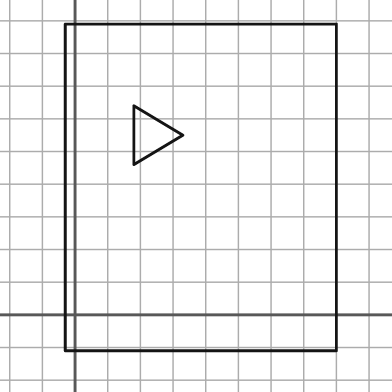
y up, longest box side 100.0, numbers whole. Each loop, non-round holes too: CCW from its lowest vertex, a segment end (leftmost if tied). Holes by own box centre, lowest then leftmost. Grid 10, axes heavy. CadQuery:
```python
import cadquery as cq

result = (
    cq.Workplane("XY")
    .moveTo(-3.0, -11.0)
    .lineTo(80.0, -11.0)
    .lineTo(80.0, 89.0)
    .lineTo(-3.0, 89.0)
    .close()
    .moveTo(18.0, 46.0)
    .lineTo(33.0, 55.0)
    .lineTo(18.0, 64.0)
    .close()
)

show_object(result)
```